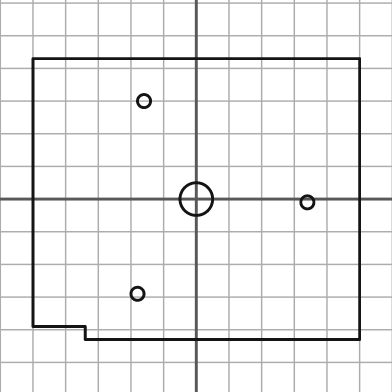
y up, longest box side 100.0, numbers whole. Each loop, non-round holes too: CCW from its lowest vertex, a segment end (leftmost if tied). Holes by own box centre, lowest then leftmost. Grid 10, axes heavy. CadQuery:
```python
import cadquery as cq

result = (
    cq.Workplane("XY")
    .moveTo(-34.0, -43.0)
    .lineTo(50.0, -43.0)
    .lineTo(50.0, 43.0)
    .lineTo(-50.0, 43.0)
    .lineTo(-50.0, -39.0)
    .lineTo(-34.0, -39.0)
    .close()
    .moveTo(-18.0, -29.0)
    .circle(2.0)
    .moveTo(34.0, -1.0)
    .circle(2.0)
    .moveTo(0.0, 0.0)
    .circle(5.0)
    .moveTo(-16.0, 30.0)
    .circle(2.0)
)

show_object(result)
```